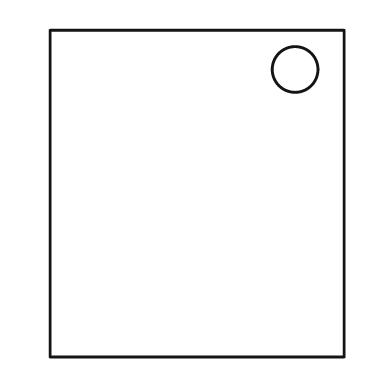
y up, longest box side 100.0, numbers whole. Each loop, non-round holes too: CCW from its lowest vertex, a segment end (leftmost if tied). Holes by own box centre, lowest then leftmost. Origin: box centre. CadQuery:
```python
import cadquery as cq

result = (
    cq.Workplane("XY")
    .moveTo(-45.0, -50.0)
    .lineTo(45.0, -50.0)
    .lineTo(45.0, 50.0)
    .lineTo(-45.0, 50.0)
    .close()
    .moveTo(30.0, 38.0)
    .circle(7.0)
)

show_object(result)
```